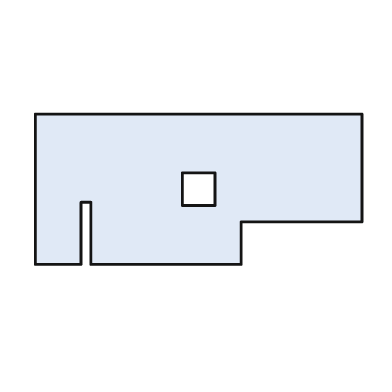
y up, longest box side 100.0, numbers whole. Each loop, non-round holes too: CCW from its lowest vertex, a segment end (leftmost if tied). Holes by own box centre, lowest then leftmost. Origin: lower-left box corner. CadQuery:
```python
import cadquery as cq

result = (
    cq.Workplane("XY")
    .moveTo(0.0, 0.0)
    .lineTo(14.0, 0.0)
    .lineTo(14.0, 19.0)
    .lineTo(17.0, 19.0)
    .lineTo(17.0, 0.0)
    .lineTo(63.0, 0.0)
    .lineTo(63.0, 13.0)
    .lineTo(100.0, 13.0)
    .lineTo(100.0, 46.0)
    .lineTo(0.0, 46.0)
    .close()
    .moveTo(45.0, 18.0)
    .lineTo(55.0, 18.0)
    .lineTo(55.0, 28.0)
    .lineTo(45.0, 28.0)
    .close()
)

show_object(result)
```